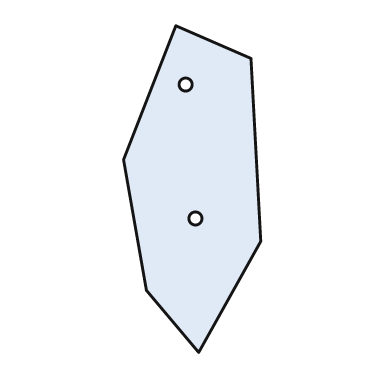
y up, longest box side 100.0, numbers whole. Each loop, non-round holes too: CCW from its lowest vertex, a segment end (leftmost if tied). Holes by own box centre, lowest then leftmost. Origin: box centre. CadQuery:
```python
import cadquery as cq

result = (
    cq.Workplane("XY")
    .moveTo(2.0, -50.0)
    .lineTo(21.0, -16.0)
    .lineTo(18.0, 40.0)
    .lineTo(-5.0, 50.0)
    .lineTo(-21.0, 9.0)
    .lineTo(-14.0, -31.0)
    .close()
    .moveTo(1.0, -9.0)
    .circle(2.0)
    .moveTo(-2.0, 32.0)
    .circle(2.0)
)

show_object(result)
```